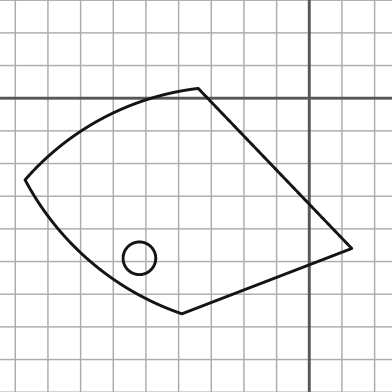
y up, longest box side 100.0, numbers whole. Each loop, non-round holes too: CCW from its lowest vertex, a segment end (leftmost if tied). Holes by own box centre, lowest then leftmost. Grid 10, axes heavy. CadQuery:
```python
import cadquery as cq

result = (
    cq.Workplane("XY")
    .moveTo(-39.0, -66.0)
    .lineTo(13.0, -46.0)
    .lineTo(-34.0, 3.0)
    .threePointArc((-63.0, -6.0), (-87.0, -25.0))
    .threePointArc((-67.0, -50.0), (-39.0, -66.0))
    .close()
    .moveTo(-52.0, -49.0)
    .circle(5.0)
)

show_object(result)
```